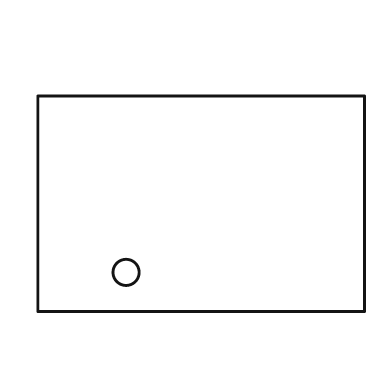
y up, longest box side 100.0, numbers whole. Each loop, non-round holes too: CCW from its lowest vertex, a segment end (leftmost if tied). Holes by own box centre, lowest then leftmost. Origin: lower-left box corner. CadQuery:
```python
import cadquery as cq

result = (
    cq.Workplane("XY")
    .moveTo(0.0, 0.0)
    .lineTo(100.0, 0.0)
    .lineTo(100.0, 66.0)
    .lineTo(0.0, 66.0)
    .close()
    .moveTo(27.0, 12.0)
    .circle(4.0)
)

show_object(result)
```